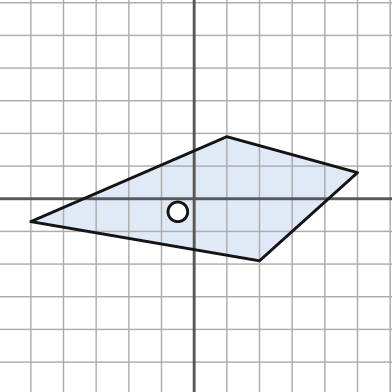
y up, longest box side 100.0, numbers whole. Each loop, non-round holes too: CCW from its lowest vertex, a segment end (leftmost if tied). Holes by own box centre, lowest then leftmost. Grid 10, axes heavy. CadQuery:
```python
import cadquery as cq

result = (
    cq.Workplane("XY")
    .moveTo(20.0, -19.0)
    .lineTo(50.0, 8.0)
    .lineTo(10.0, 19.0)
    .lineTo(-50.0, -7.0)
    .close()
    .moveTo(-5.0, -4.0)
    .circle(3.0)
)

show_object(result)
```